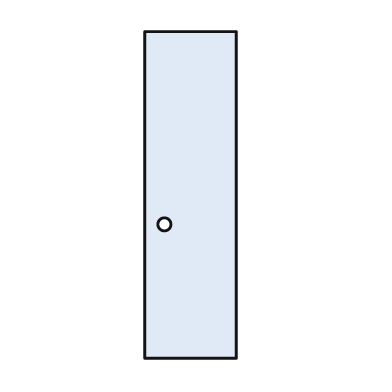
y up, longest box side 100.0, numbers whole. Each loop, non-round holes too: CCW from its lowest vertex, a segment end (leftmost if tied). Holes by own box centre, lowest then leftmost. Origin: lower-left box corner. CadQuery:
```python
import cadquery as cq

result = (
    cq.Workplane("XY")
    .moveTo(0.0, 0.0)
    .lineTo(28.0, 0.0)
    .lineTo(28.0, 100.0)
    .lineTo(0.0, 100.0)
    .close()
    .moveTo(6.0, 41.0)
    .circle(2.0)
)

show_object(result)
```